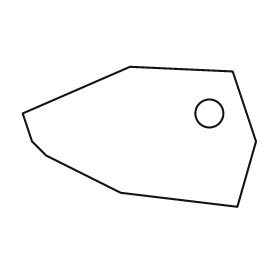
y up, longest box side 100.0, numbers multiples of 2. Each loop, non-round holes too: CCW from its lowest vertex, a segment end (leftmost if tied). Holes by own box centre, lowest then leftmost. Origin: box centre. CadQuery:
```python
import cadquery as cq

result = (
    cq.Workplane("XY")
    .moveTo(42.0, -30.0)
    .lineTo(50.0, -2.0)
    .lineTo(40.0, 28.0)
    .lineTo(-4.0, 30.0)
    .lineTo(-50.0, 10.0)
    .lineTo(-46.0, -2.0)
    .lineTo(-40.0, -8.0)
    .lineTo(-8.0, -24.0)
    .close()
    .moveTo(30.0, 10.0)
    .circle(6.0)
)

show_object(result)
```